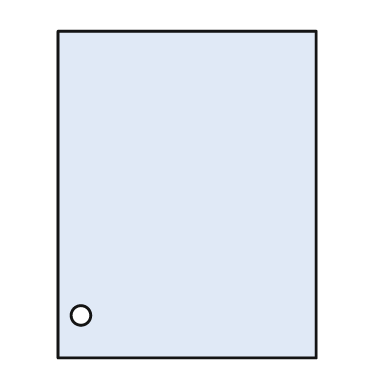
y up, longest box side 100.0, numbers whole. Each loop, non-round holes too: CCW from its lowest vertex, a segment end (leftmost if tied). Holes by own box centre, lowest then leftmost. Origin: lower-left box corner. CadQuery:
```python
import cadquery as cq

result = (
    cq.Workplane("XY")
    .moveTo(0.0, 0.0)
    .lineTo(79.0, 0.0)
    .lineTo(79.0, 100.0)
    .lineTo(0.0, 100.0)
    .close()
    .moveTo(7.0, 13.0)
    .circle(3.0)
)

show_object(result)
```